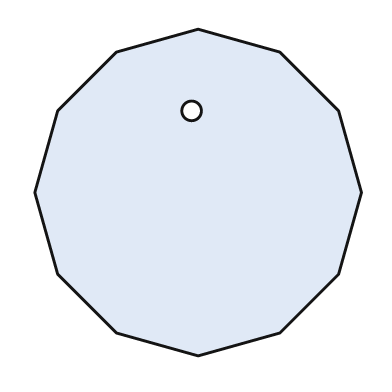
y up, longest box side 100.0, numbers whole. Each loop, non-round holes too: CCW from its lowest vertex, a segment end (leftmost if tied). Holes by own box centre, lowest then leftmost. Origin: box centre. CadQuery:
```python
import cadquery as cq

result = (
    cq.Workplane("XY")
    .moveTo(0.0, -50.0)
    .lineTo(25.0, -43.0)
    .lineTo(43.0, -25.0)
    .lineTo(50.0, 0.0)
    .lineTo(43.0, 25.0)
    .lineTo(25.0, 43.0)
    .lineTo(0.0, 50.0)
    .lineTo(-25.0, 43.0)
    .lineTo(-43.0, 25.0)
    .lineTo(-50.0, 0.0)
    .lineTo(-43.0, -25.0)
    .lineTo(-25.0, -43.0)
    .close()
    .moveTo(-2.0, 25.0)
    .circle(3.0)
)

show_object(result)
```